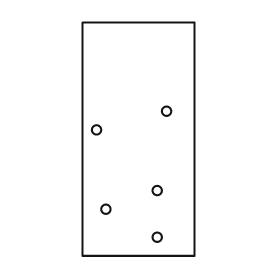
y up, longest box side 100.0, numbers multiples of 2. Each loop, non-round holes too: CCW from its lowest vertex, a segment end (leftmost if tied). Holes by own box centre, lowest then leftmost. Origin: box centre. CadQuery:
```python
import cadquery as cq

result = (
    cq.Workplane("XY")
    .moveTo(-24.0, -50.0)
    .lineTo(24.0, -50.0)
    .lineTo(24.0, 50.0)
    .lineTo(-24.0, 50.0)
    .close()
    .moveTo(8.0, -42.0)
    .circle(2.0)
    .moveTo(-14.0, -30.0)
    .circle(2.0)
    .moveTo(8.0, -22.0)
    .circle(2.0)
    .moveTo(-18.0, 4.0)
    .circle(2.0)
    .moveTo(12.0, 12.0)
    .circle(2.0)
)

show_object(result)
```